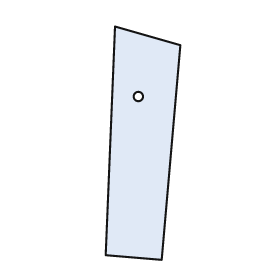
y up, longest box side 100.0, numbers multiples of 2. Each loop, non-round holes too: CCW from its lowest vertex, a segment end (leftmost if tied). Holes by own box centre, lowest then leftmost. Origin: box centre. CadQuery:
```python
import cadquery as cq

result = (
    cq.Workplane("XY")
    .moveTo(8.0, -50.0)
    .lineTo(16.0, 42.0)
    .lineTo(-12.0, 50.0)
    .lineTo(-16.0, -48.0)
    .close()
    .moveTo(-2.0, 20.0)
    .circle(2.0)
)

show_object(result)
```